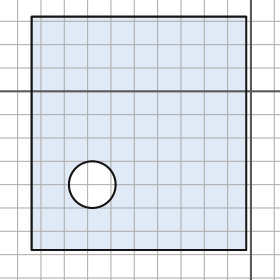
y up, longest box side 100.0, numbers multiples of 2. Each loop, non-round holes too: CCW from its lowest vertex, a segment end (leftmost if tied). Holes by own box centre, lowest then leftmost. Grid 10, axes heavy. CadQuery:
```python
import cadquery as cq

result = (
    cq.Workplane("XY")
    .moveTo(-94.0, -68.0)
    .lineTo(-2.0, -68.0)
    .lineTo(-2.0, 32.0)
    .lineTo(-94.0, 32.0)
    .close()
    .moveTo(-68.0, -40.0)
    .circle(10.0)
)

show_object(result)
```